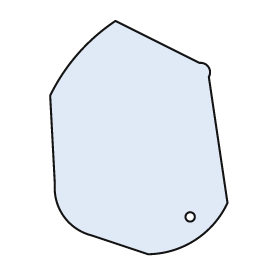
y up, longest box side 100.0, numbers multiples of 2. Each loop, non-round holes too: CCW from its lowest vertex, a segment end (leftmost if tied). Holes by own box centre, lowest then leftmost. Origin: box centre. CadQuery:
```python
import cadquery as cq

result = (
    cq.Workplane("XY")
    .moveTo(4.0, -50.0)
    .threePointArc((24.0, -44.0), (38.0, -28.0))
    .lineTo(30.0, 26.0)
    .threePointArc((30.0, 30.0), (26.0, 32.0))
    .lineTo(-10.0, 50.0)
    .threePointArc((-26.0, 36.0), (-38.0, 18.0))
    .lineTo(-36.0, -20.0)
    .threePointArc((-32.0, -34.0), (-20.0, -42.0))
    .close()
    .moveTo(22.0, -34.0)
    .circle(2.0)
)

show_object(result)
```